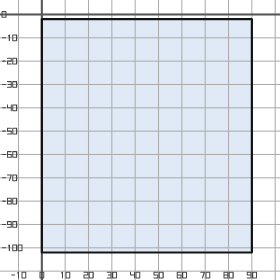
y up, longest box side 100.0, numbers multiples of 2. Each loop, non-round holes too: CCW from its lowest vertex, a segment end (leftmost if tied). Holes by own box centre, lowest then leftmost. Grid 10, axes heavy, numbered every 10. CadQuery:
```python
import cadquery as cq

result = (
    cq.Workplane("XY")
    .moveTo(0.0, -102.0)
    .lineTo(90.0, -102.0)
    .lineTo(90.0, -2.0)
    .lineTo(0.0, -2.0)
    .close()
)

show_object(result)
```